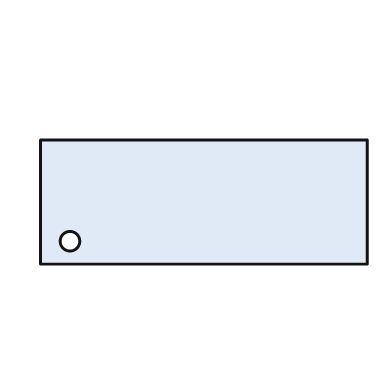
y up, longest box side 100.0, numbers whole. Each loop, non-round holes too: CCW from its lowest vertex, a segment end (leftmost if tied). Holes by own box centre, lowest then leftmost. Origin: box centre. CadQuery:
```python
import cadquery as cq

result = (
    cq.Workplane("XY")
    .moveTo(-50.0, -19.0)
    .lineTo(50.0, -19.0)
    .lineTo(50.0, 19.0)
    .lineTo(-50.0, 19.0)
    .close()
    .moveTo(-41.0, -12.0)
    .circle(3.0)
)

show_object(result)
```